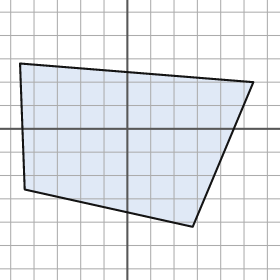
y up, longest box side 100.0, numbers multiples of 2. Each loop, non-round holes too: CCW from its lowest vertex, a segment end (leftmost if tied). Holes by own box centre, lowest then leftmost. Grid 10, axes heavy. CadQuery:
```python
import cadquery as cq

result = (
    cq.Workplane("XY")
    .moveTo(28.0, -42.0)
    .lineTo(54.0, 20.0)
    .lineTo(-46.0, 28.0)
    .lineTo(-44.0, -26.0)
    .close()
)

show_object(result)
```